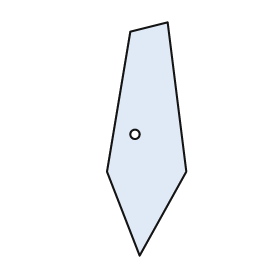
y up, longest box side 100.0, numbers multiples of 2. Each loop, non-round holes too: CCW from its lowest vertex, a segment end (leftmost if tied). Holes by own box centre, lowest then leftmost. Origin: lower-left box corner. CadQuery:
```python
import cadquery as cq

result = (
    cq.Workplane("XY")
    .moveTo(14.0, 0.0)
    .lineTo(34.0, 36.0)
    .lineTo(26.0, 100.0)
    .lineTo(10.0, 96.0)
    .lineTo(0.0, 36.0)
    .close()
    .moveTo(12.0, 52.0)
    .circle(2.0)
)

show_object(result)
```